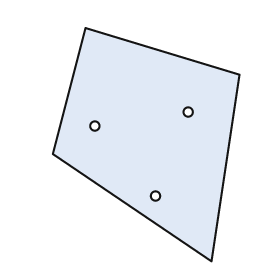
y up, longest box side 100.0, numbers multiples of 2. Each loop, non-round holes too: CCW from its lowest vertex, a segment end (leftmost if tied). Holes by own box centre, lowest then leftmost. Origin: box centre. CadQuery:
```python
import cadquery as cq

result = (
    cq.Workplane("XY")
    .moveTo(28.0, -50.0)
    .lineTo(40.0, 30.0)
    .lineTo(-26.0, 50.0)
    .lineTo(-40.0, -4.0)
    .close()
    .moveTo(4.0, -22.0)
    .circle(2.0)
    .moveTo(-22.0, 8.0)
    .circle(2.0)
    .moveTo(18.0, 14.0)
    .circle(2.0)
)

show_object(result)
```